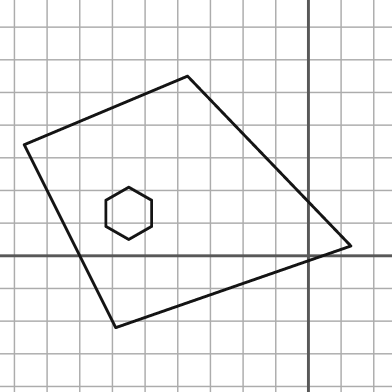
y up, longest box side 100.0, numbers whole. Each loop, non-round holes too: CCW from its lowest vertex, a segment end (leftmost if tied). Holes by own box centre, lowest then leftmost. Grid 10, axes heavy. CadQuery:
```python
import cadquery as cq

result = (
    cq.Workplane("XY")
    .moveTo(-59.0, -22.0)
    .lineTo(13.0, 3.0)
    .lineTo(-37.0, 55.0)
    .lineTo(-87.0, 34.0)
    .close()
    .moveTo(-55.0, 5.0)
    .lineTo(-48.0, 9.0)
    .lineTo(-48.0, 17.0)
    .lineTo(-55.0, 21.0)
    .lineTo(-62.0, 17.0)
    .lineTo(-62.0, 9.0)
    .close()
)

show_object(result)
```